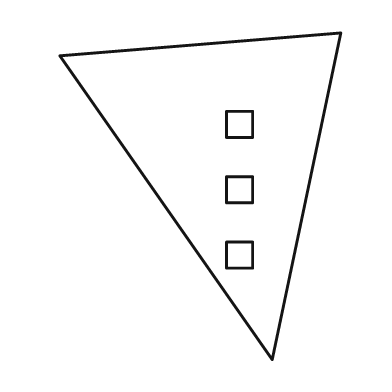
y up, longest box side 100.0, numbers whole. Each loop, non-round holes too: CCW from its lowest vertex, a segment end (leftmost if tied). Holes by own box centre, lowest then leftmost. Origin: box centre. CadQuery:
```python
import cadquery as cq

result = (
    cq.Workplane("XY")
    .moveTo(22.0, -50.0)
    .lineTo(43.0, 50.0)
    .lineTo(-43.0, 43.0)
    .close()
    .moveTo(8.0, -22.0)
    .lineTo(16.0, -22.0)
    .lineTo(16.0, -14.0)
    .lineTo(8.0, -14.0)
    .close()
    .moveTo(8.0, -2.0)
    .lineTo(16.0, -2.0)
    .lineTo(16.0, 6.0)
    .lineTo(8.0, 6.0)
    .close()
    .moveTo(8.0, 18.0)
    .lineTo(16.0, 18.0)
    .lineTo(16.0, 26.0)
    .lineTo(8.0, 26.0)
    .close()
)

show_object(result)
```